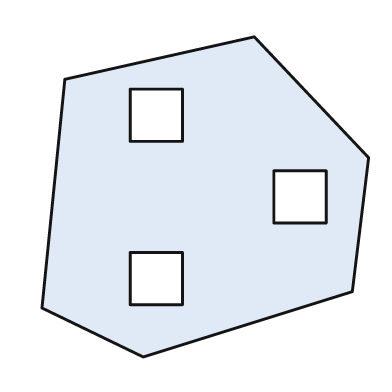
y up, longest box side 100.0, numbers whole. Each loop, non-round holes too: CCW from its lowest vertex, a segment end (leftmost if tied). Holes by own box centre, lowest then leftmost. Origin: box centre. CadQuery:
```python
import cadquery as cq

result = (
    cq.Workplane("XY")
    .moveTo(-19.0, -49.0)
    .lineTo(45.0, -29.0)
    .lineTo(50.0, 12.0)
    .lineTo(15.0, 49.0)
    .lineTo(-43.0, 36.0)
    .lineTo(-50.0, -34.0)
    .close()
    .moveTo(-23.0, -33.0)
    .lineTo(-7.0, -33.0)
    .lineTo(-7.0, -17.0)
    .lineTo(-23.0, -17.0)
    .close()
    .moveTo(21.0, -8.0)
    .lineTo(37.0, -8.0)
    .lineTo(37.0, 8.0)
    .lineTo(21.0, 8.0)
    .close()
    .moveTo(-23.0, 17.0)
    .lineTo(-7.0, 17.0)
    .lineTo(-7.0, 33.0)
    .lineTo(-23.0, 33.0)
    .close()
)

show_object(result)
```